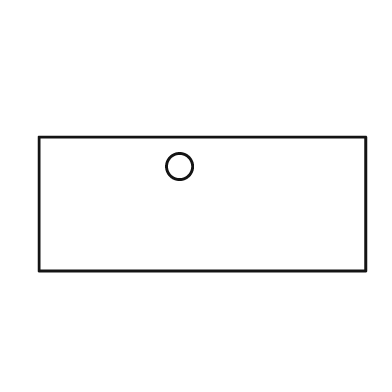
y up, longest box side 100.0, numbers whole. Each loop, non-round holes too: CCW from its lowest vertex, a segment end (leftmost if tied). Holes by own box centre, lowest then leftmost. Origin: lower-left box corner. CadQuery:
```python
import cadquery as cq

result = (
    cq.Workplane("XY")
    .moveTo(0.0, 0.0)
    .lineTo(100.0, 0.0)
    .lineTo(100.0, 41.0)
    .lineTo(0.0, 41.0)
    .close()
    .moveTo(43.0, 32.0)
    .circle(4.0)
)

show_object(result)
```